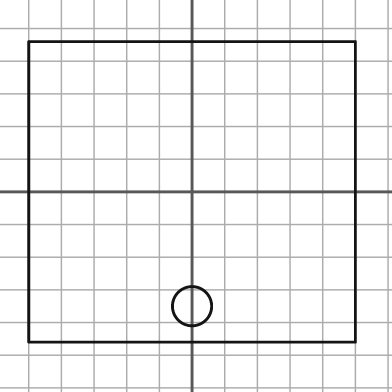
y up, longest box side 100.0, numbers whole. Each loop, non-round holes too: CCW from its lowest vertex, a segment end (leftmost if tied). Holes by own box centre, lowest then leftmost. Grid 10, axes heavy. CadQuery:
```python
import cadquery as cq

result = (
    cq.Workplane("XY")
    .moveTo(-50.0, -46.0)
    .lineTo(50.0, -46.0)
    .lineTo(50.0, 46.0)
    .lineTo(-50.0, 46.0)
    .close()
    .moveTo(0.0, -35.0)
    .circle(6.0)
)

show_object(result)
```